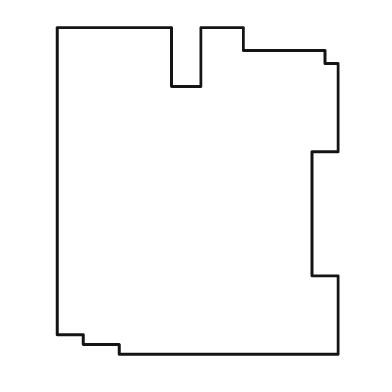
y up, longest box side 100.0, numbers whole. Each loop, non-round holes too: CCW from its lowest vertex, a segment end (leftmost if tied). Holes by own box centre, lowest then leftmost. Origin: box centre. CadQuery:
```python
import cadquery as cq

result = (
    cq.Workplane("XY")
    .moveTo(-24.0, -50.0)
    .lineTo(43.0, -50.0)
    .lineTo(43.0, -26.0)
    .lineTo(35.0, -26.0)
    .lineTo(35.0, 12.0)
    .lineTo(43.0, 12.0)
    .lineTo(43.0, 39.0)
    .lineTo(39.0, 39.0)
    .lineTo(39.0, 43.0)
    .lineTo(14.0, 43.0)
    .lineTo(14.0, 50.0)
    .lineTo(1.0, 50.0)
    .lineTo(1.0, 32.0)
    .lineTo(-8.0, 32.0)
    .lineTo(-8.0, 50.0)
    .lineTo(-43.0, 50.0)
    .lineTo(-43.0, -44.0)
    .lineTo(-35.0, -44.0)
    .lineTo(-35.0, -47.0)
    .lineTo(-24.0, -47.0)
    .close()
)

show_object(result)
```